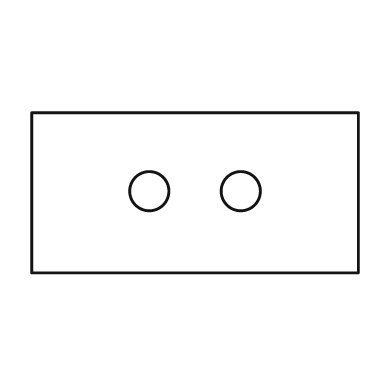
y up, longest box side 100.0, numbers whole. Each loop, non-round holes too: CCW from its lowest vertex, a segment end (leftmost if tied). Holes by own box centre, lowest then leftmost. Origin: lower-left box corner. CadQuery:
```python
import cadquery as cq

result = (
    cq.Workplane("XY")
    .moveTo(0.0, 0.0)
    .lineTo(100.0, 0.0)
    .lineTo(100.0, 49.0)
    .lineTo(0.0, 49.0)
    .close()
    .moveTo(36.0, 25.0)
    .circle(6.0)
    .moveTo(64.0, 25.0)
    .circle(6.0)
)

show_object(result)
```